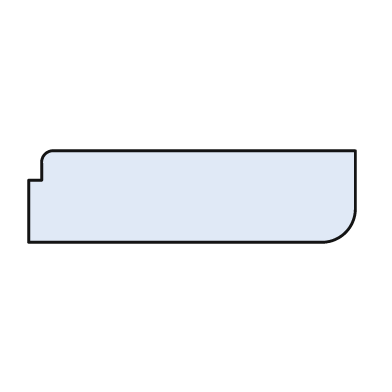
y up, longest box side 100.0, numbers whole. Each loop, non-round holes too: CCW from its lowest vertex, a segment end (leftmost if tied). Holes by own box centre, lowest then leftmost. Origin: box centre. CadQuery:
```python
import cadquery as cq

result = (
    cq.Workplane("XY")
    .moveTo(-50.0, -14.0)
    .lineTo(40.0, -14.0)
    .threePointArc((47.0, -11.0), (50.0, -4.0))
    .lineTo(50.0, 14.0)
    .lineTo(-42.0, 14.0)
    .threePointArc((-45.0, 13.0), (-46.0, 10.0))
    .lineTo(-46.0, 5.0)
    .lineTo(-50.0, 5.0)
    .close()
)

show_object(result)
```